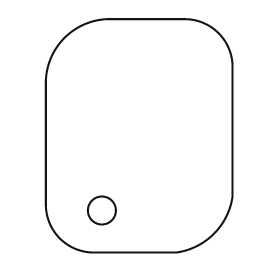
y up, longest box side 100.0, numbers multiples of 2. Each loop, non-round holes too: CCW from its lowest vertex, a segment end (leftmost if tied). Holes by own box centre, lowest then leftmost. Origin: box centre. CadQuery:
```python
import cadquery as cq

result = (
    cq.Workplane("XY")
    .moveTo(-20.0, -50.0)
    .lineTo(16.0, -50.0)
    .threePointArc((32.0, -42.0), (40.0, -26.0))
    .lineTo(40.0, 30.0)
    .threePointArc((34.0, 44.0), (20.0, 50.0))
    .lineTo(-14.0, 50.0)
    .threePointArc((-32.0, 42.0), (-40.0, 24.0))
    .lineTo(-40.0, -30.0)
    .threePointArc((-34.0, -44.0), (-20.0, -50.0))
    .close()
    .moveTo(-16.0, -32.0)
    .circle(6.0)
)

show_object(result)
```